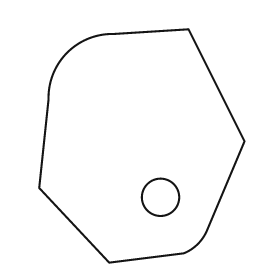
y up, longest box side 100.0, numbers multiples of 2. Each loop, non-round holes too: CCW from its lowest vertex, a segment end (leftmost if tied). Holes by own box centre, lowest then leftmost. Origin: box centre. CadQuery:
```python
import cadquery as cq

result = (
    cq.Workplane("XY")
    .moveTo(-14.0, -50.0)
    .lineTo(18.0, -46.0)
    .threePointArc((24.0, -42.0), (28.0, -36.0))
    .lineTo(44.0, 2.0)
    .lineTo(20.0, 50.0)
    .lineTo(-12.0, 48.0)
    .threePointArc((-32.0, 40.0), (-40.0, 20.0))
    .lineTo(-44.0, -18.0)
    .close()
    .moveTo(8.0, -22.0)
    .circle(8.0)
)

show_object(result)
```